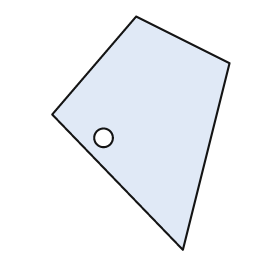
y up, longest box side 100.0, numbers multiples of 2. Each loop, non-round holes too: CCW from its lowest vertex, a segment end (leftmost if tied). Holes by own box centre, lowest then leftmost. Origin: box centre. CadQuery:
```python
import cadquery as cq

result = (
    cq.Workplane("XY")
    .moveTo(18.0, -50.0)
    .lineTo(38.0, 30.0)
    .lineTo(-2.0, 50.0)
    .lineTo(-38.0, 8.0)
    .close()
    .moveTo(-16.0, -2.0)
    .circle(4.0)
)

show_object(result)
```